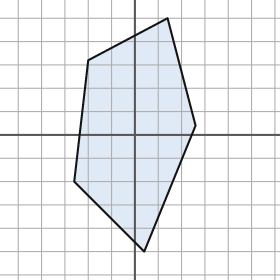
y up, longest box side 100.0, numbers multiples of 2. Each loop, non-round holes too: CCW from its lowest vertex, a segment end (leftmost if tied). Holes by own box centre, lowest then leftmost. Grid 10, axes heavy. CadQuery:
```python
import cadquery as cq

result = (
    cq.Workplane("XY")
    .moveTo(4.0, -50.0)
    .lineTo(26.0, 4.0)
    .lineTo(14.0, 50.0)
    .lineTo(-20.0, 32.0)
    .lineTo(-26.0, -20.0)
    .close()
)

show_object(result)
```